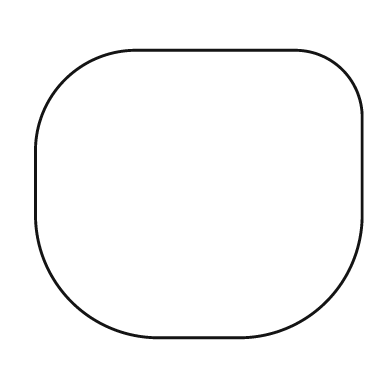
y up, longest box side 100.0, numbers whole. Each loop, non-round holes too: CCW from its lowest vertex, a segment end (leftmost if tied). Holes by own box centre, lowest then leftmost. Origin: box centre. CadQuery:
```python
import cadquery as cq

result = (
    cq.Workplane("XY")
    .moveTo(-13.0, -44.0)
    .lineTo(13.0, -44.0)
    .threePointArc((39.0, -33.0), (50.0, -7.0))
    .lineTo(50.0, 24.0)
    .threePointArc((44.0, 38.0), (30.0, 44.0))
    .lineTo(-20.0, 44.0)
    .threePointArc((-41.0, 35.0), (-50.0, 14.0))
    .lineTo(-50.0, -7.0)
    .threePointArc((-39.0, -33.0), (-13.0, -44.0))
    .close()
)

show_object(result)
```